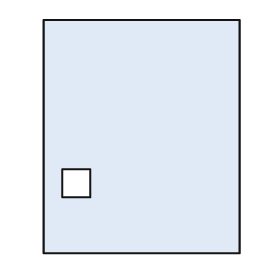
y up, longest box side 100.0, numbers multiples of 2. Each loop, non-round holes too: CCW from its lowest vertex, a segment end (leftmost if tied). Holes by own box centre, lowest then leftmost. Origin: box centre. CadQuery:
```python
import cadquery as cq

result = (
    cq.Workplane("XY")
    .moveTo(-42.0, -50.0)
    .lineTo(42.0, -50.0)
    .lineTo(42.0, 50.0)
    .lineTo(-42.0, 50.0)
    .close()
    .moveTo(-34.0, -26.0)
    .lineTo(-22.0, -26.0)
    .lineTo(-22.0, -14.0)
    .lineTo(-34.0, -14.0)
    .close()
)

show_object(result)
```